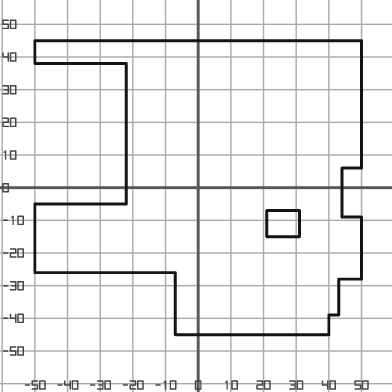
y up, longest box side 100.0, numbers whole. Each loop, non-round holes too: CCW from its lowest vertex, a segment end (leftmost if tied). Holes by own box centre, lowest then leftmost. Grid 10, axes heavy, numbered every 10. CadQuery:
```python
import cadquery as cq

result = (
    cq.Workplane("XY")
    .moveTo(-7.0, -45.0)
    .lineTo(40.0, -45.0)
    .lineTo(40.0, -39.0)
    .lineTo(43.0, -39.0)
    .lineTo(43.0, -28.0)
    .lineTo(50.0, -28.0)
    .lineTo(50.0, -9.0)
    .lineTo(44.0, -9.0)
    .lineTo(44.0, 6.0)
    .lineTo(50.0, 6.0)
    .lineTo(50.0, 45.0)
    .lineTo(-50.0, 45.0)
    .lineTo(-50.0, 38.0)
    .lineTo(-22.0, 38.0)
    .lineTo(-22.0, -5.0)
    .lineTo(-50.0, -5.0)
    .lineTo(-50.0, -26.0)
    .lineTo(-7.0, -26.0)
    .close()
    .moveTo(21.0, -15.0)
    .lineTo(31.0, -15.0)
    .lineTo(31.0, -7.0)
    .lineTo(21.0, -7.0)
    .close()
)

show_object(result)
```